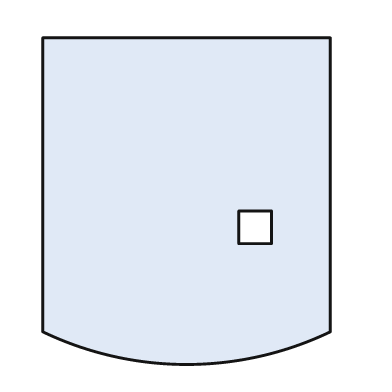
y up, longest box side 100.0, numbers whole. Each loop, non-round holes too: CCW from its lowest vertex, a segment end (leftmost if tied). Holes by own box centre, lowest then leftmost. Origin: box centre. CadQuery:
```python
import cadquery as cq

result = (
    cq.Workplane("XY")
    .moveTo(-44.0, -40.0)
    .threePointArc((0.0, -50.0), (44.0, -40.0))
    .lineTo(44.0, 50.0)
    .lineTo(-44.0, 50.0)
    .close()
    .moveTo(16.0, -13.0)
    .lineTo(26.0, -13.0)
    .lineTo(26.0, -3.0)
    .lineTo(16.0, -3.0)
    .close()
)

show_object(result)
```